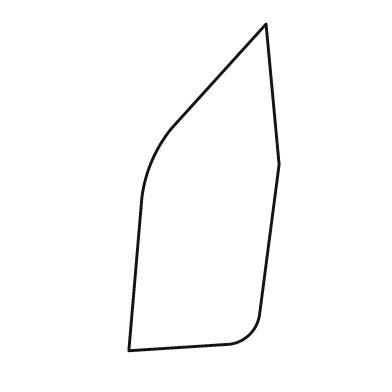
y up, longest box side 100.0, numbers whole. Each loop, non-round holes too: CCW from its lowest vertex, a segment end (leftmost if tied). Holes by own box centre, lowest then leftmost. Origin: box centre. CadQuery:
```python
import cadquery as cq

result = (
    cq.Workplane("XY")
    .moveTo(-23.0, -50.0)
    .lineTo(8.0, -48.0)
    .threePointArc((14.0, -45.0), (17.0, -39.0))
    .lineTo(23.0, 7.0)
    .lineTo(19.0, 50.0)
    .lineTo(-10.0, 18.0)
    .threePointArc((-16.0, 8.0), (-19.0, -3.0))
    .close()
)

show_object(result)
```